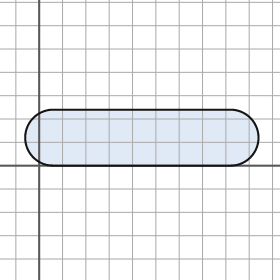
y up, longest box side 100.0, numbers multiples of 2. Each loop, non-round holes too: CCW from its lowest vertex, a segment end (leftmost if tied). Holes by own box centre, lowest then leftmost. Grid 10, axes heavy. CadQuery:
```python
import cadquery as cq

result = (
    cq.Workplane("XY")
    .moveTo(6.0, 0.0)
    .lineTo(82.0, 0.0)
    .threePointArc((94.0, 12.0), (82.0, 24.0))
    .lineTo(6.0, 24.0)
    .threePointArc((-6.0, 12.0), (6.0, 0.0))
    .close()
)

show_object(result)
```